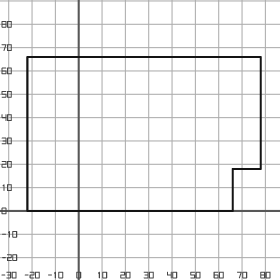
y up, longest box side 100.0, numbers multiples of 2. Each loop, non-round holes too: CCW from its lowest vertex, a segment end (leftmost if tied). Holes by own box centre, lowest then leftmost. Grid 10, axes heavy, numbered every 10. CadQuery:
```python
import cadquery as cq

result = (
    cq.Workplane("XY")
    .moveTo(-22.0, 0.0)
    .lineTo(66.0, 0.0)
    .lineTo(66.0, 18.0)
    .lineTo(78.0, 18.0)
    .lineTo(78.0, 66.0)
    .lineTo(-22.0, 66.0)
    .close()
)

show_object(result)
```